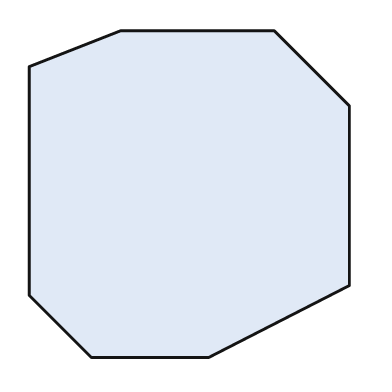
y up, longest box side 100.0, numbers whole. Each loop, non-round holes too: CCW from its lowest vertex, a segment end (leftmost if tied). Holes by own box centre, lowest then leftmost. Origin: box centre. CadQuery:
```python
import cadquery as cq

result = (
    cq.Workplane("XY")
    .moveTo(-30.0, -50.0)
    .lineTo(6.0, -50.0)
    .lineTo(49.0, -28.0)
    .lineTo(49.0, 27.0)
    .lineTo(26.0, 50.0)
    .lineTo(-21.0, 50.0)
    .lineTo(-49.0, 39.0)
    .lineTo(-49.0, -31.0)
    .close()
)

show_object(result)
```